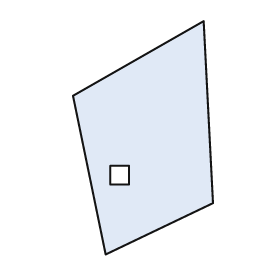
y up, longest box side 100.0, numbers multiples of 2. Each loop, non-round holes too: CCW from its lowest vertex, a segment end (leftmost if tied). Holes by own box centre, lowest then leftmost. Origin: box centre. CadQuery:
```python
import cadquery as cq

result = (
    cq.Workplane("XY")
    .moveTo(-16.0, -50.0)
    .lineTo(30.0, -28.0)
    .lineTo(26.0, 50.0)
    .lineTo(-30.0, 18.0)
    .close()
    .moveTo(-14.0, -20.0)
    .lineTo(-6.0, -20.0)
    .lineTo(-6.0, -12.0)
    .lineTo(-14.0, -12.0)
    .close()
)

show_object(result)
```